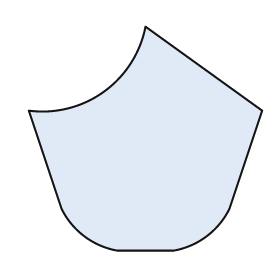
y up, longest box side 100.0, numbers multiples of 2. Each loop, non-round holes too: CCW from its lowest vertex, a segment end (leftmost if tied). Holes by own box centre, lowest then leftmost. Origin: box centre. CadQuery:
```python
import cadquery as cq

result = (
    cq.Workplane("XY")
    .moveTo(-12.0, -48.0)
    .lineTo(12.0, -48.0)
    .threePointArc((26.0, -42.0), (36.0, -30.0))
    .lineTo(50.0, 12.0)
    .lineTo(0.0, 48.0)
    .threePointArc((-18.0, 20.0), (-50.0, 12.0))
    .lineTo(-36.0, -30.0)
    .threePointArc((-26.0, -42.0), (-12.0, -48.0))
    .close()
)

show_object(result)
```